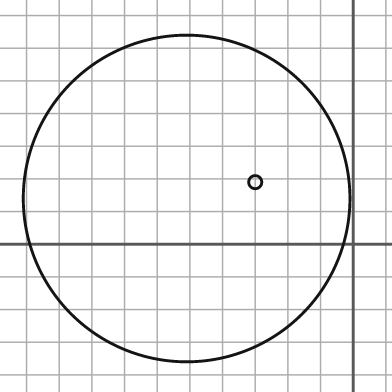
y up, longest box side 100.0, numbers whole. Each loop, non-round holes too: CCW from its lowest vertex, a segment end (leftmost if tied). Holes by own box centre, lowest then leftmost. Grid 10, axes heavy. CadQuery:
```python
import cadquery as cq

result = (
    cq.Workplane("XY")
    .moveTo(-51.0, 14.0)
    .circle(50.0)
    .moveTo(-30.0, 19.0)
    .circle(2.0)
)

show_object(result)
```